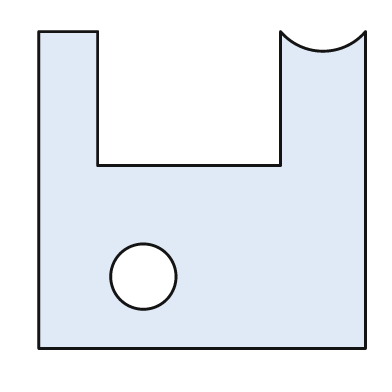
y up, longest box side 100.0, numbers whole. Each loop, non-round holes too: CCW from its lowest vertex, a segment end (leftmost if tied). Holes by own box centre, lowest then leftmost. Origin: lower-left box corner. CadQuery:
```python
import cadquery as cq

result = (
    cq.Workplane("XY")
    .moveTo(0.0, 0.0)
    .lineTo(100.0, 0.0)
    .lineTo(100.0, 97.0)
    .threePointArc((87.0, 91.0), (74.0, 97.0))
    .lineTo(74.0, 56.0)
    .lineTo(18.0, 56.0)
    .lineTo(18.0, 97.0)
    .lineTo(0.0, 97.0)
    .close()
    .moveTo(32.0, 22.0)
    .circle(10.0)
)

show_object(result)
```